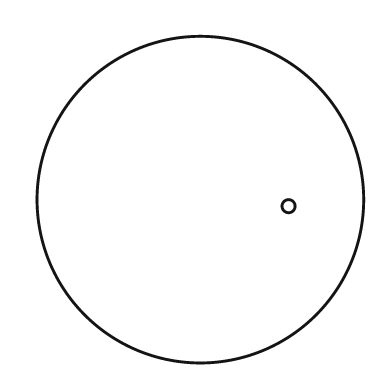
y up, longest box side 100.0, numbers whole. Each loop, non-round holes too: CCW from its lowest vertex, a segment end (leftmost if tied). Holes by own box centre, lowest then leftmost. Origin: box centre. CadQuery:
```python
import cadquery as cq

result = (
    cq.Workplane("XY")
    .moveTo(0.0, 0.0)
    .circle(50.0)
    .moveTo(27.0, -2.0)
    .circle(2.0)
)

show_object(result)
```